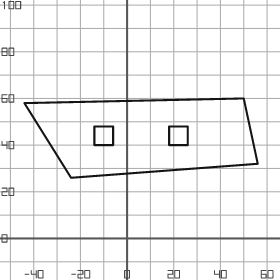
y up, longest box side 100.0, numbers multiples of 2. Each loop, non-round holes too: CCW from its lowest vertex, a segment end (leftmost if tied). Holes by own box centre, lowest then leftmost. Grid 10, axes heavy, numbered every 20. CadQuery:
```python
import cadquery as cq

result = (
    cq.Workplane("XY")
    .moveTo(-24.0, 26.0)
    .lineTo(56.0, 32.0)
    .lineTo(50.0, 60.0)
    .lineTo(-44.0, 58.0)
    .close()
    .moveTo(-14.0, 40.0)
    .lineTo(-6.0, 40.0)
    .lineTo(-6.0, 48.0)
    .lineTo(-14.0, 48.0)
    .close()
    .moveTo(18.0, 40.0)
    .lineTo(26.0, 40.0)
    .lineTo(26.0, 48.0)
    .lineTo(18.0, 48.0)
    .close()
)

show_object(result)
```